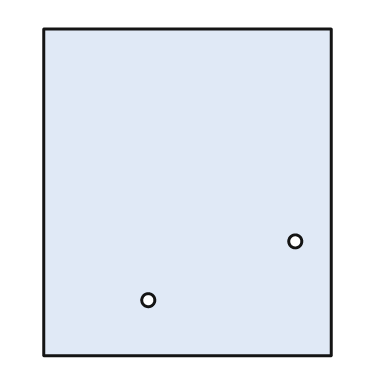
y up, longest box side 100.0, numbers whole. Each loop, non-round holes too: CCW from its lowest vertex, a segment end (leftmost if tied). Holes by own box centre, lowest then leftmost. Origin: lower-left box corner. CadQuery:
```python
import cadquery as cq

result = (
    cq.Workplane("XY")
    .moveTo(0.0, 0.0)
    .lineTo(88.0, 0.0)
    .lineTo(88.0, 100.0)
    .lineTo(0.0, 100.0)
    .close()
    .moveTo(32.0, 17.0)
    .circle(2.0)
    .moveTo(77.0, 35.0)
    .circle(2.0)
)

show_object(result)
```